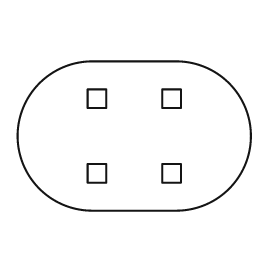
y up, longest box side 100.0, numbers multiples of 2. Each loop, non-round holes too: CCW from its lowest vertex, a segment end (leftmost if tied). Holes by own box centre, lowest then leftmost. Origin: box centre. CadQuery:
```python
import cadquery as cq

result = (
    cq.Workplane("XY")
    .moveTo(-18.0, -32.0)
    .lineTo(18.0, -32.0)
    .threePointArc((50.0, 0.0), (18.0, 32.0))
    .lineTo(-18.0, 32.0)
    .threePointArc((-50.0, 0.0), (-18.0, -32.0))
    .close()
    .moveTo(-20.0, -20.0)
    .lineTo(-12.0, -20.0)
    .lineTo(-12.0, -12.0)
    .lineTo(-20.0, -12.0)
    .close()
    .moveTo(12.0, -20.0)
    .lineTo(20.0, -20.0)
    .lineTo(20.0, -12.0)
    .lineTo(12.0, -12.0)
    .close()
    .moveTo(-20.0, 12.0)
    .lineTo(-12.0, 12.0)
    .lineTo(-12.0, 20.0)
    .lineTo(-20.0, 20.0)
    .close()
    .moveTo(12.0, 12.0)
    .lineTo(20.0, 12.0)
    .lineTo(20.0, 20.0)
    .lineTo(12.0, 20.0)
    .close()
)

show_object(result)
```